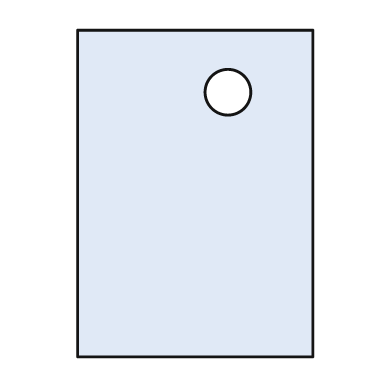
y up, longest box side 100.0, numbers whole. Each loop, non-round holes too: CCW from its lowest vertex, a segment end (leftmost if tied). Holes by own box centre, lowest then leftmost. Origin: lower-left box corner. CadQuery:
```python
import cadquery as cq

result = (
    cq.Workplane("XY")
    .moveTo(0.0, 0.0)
    .lineTo(72.0, 0.0)
    .lineTo(72.0, 100.0)
    .lineTo(0.0, 100.0)
    .close()
    .moveTo(46.0, 81.0)
    .circle(7.0)
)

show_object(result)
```